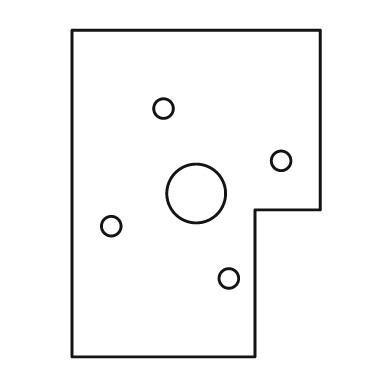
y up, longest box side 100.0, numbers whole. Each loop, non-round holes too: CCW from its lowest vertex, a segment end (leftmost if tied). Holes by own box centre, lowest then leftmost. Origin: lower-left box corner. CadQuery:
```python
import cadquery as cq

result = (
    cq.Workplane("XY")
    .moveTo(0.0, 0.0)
    .lineTo(56.0, 0.0)
    .lineTo(56.0, 45.0)
    .lineTo(76.0, 45.0)
    .lineTo(76.0, 100.0)
    .lineTo(0.0, 100.0)
    .close()
    .moveTo(48.0, 24.0)
    .circle(3.0)
    .moveTo(12.0, 40.0)
    .circle(3.0)
    .moveTo(38.0, 50.0)
    .circle(9.0)
    .moveTo(64.0, 60.0)
    .circle(3.0)
    .moveTo(28.0, 76.0)
    .circle(3.0)
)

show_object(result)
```